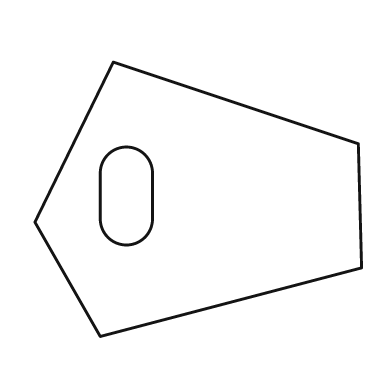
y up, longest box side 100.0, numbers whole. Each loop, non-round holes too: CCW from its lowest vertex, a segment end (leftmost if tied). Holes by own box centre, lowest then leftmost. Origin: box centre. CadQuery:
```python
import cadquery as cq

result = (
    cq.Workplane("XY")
    .moveTo(-30.0, -42.0)
    .lineTo(50.0, -21.0)
    .lineTo(49.0, 17.0)
    .lineTo(-26.0, 42.0)
    .lineTo(-50.0, -7.0)
    .close()
    .moveTo(-30.0, -6.0)
    .threePointArc((-22.0, -14.0), (-14.0, -6.0))
    .lineTo(-14.0, 8.0)
    .threePointArc((-22.0, 16.0), (-30.0, 8.0))
    .close()
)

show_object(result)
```